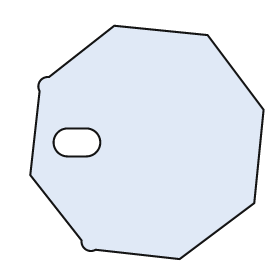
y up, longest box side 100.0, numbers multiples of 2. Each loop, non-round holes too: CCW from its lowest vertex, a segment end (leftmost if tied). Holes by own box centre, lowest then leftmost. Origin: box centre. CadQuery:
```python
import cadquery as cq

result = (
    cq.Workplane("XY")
    .moveTo(14.0, -50.0)
    .lineTo(46.0, -26.0)
    .lineTo(50.0, 14.0)
    .lineTo(26.0, 46.0)
    .lineTo(-14.0, 50.0)
    .lineTo(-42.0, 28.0)
    .threePointArc((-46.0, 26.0), (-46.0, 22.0))
    .lineTo(-50.0, -14.0)
    .lineTo(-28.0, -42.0)
    .threePointArc((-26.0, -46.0), (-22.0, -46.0))
    .close()
    .moveTo(-34.0, -6.0)
    .lineTo(-26.0, -6.0)
    .threePointArc((-20.0, 0.0), (-26.0, 6.0))
    .lineTo(-34.0, 6.0)
    .threePointArc((-40.0, 0.0), (-34.0, -6.0))
    .close()
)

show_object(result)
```